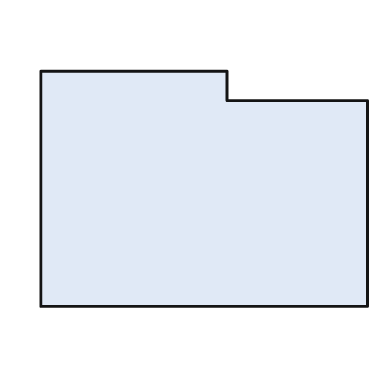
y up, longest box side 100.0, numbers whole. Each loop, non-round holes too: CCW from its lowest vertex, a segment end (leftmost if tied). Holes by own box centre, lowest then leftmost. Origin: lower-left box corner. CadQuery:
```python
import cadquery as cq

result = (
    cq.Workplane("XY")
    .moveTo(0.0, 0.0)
    .lineTo(100.0, 0.0)
    .lineTo(100.0, 63.0)
    .lineTo(57.0, 63.0)
    .lineTo(57.0, 72.0)
    .lineTo(0.0, 72.0)
    .close()
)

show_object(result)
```